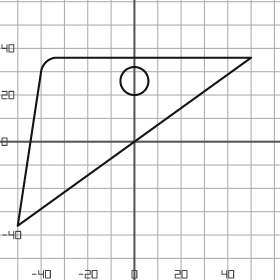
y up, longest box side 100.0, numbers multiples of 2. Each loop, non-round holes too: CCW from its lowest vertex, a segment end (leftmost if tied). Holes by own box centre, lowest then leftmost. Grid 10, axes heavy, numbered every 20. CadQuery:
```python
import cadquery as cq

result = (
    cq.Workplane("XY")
    .moveTo(-50.0, -36.0)
    .lineTo(50.0, 36.0)
    .lineTo(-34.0, 36.0)
    .threePointArc((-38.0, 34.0), (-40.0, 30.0))
    .close()
    .moveTo(0.0, 26.0)
    .circle(6.0)
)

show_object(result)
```